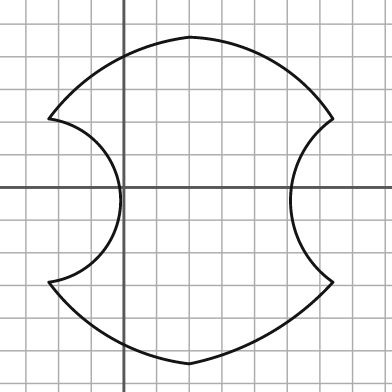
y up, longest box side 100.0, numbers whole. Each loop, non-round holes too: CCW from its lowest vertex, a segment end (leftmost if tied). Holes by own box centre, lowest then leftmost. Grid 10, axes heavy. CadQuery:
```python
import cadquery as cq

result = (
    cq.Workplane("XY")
    .moveTo(20.0, -54.0)
    .threePointArc((44.0, -45.0), (64.0, -29.0))
    .threePointArc((51.0, -4.0), (64.0, 21.0))
    .threePointArc((45.0, 39.0), (20.0, 46.0))
    .threePointArc((-4.0, 38.0), (-23.0, 21.0))
    .threePointArc((-1.0, -4.0), (-23.0, -29.0))
    .threePointArc((-4.0, -46.0), (20.0, -54.0))
    .close()
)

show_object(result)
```